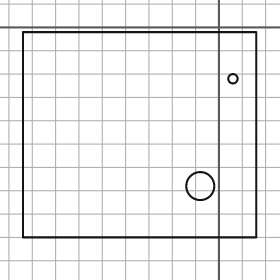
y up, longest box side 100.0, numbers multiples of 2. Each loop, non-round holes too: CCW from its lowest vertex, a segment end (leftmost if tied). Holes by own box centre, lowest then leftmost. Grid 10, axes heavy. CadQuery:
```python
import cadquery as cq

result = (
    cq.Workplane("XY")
    .moveTo(-84.0, -90.0)
    .lineTo(16.0, -90.0)
    .lineTo(16.0, -2.0)
    .lineTo(-84.0, -2.0)
    .close()
    .moveTo(-8.0, -68.0)
    .circle(6.0)
    .moveTo(6.0, -22.0)
    .circle(2.0)
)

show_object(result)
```